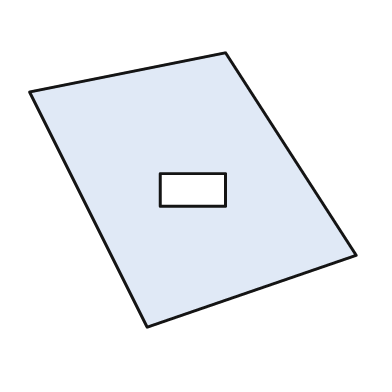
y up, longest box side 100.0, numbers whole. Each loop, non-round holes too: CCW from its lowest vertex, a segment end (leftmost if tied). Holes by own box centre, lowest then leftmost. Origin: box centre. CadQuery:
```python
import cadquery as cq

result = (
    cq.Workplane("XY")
    .moveTo(-14.0, -42.0)
    .lineTo(50.0, -20.0)
    .lineTo(10.0, 42.0)
    .lineTo(-50.0, 30.0)
    .close()
    .moveTo(-10.0, -5.0)
    .lineTo(10.0, -5.0)
    .lineTo(10.0, 5.0)
    .lineTo(-10.0, 5.0)
    .close()
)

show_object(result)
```